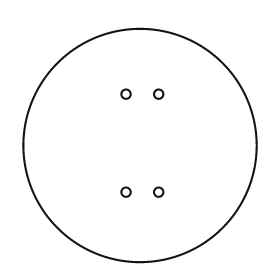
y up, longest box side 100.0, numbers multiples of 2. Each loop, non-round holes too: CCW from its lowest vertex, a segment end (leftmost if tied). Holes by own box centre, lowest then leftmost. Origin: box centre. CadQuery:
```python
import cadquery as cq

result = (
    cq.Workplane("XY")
    .moveTo(0.0, 0.0)
    .circle(50.0)
    .moveTo(-6.0, -20.0)
    .circle(2.0)
    .moveTo(8.0, -20.0)
    .circle(2.0)
    .moveTo(-6.0, 22.0)
    .circle(2.0)
    .moveTo(8.0, 22.0)
    .circle(2.0)
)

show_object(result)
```